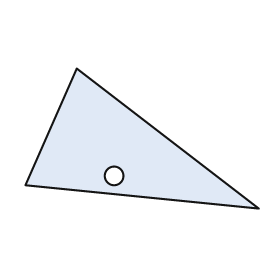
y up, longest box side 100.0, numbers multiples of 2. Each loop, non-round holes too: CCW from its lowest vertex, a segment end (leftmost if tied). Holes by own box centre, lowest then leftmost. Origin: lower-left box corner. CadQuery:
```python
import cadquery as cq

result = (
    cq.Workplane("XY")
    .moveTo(100.0, 0.0)
    .lineTo(22.0, 60.0)
    .lineTo(0.0, 10.0)
    .close()
    .moveTo(38.0, 14.0)
    .circle(4.0)
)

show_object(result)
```